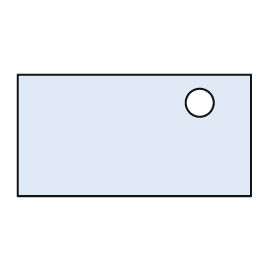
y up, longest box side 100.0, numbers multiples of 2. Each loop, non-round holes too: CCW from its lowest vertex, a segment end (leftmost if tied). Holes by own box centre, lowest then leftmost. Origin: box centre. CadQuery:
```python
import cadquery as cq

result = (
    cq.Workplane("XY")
    .moveTo(-50.0, -26.0)
    .lineTo(50.0, -26.0)
    .lineTo(50.0, 26.0)
    .lineTo(-50.0, 26.0)
    .close()
    .moveTo(28.0, 14.0)
    .circle(6.0)
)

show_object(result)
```